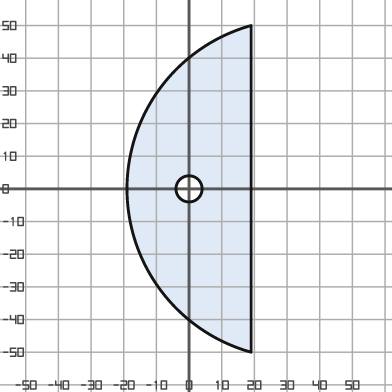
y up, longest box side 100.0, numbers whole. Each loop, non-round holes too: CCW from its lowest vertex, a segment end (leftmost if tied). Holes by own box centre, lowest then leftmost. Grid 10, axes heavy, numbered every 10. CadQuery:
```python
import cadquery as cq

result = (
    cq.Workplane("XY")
    .moveTo(19.0, -50.0)
    .lineTo(19.0, 50.0)
    .threePointArc((-19.0, 0.0), (19.0, -50.0))
    .close()
    .moveTo(0.0, 0.0)
    .circle(4.0)
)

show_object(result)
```